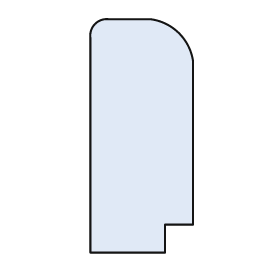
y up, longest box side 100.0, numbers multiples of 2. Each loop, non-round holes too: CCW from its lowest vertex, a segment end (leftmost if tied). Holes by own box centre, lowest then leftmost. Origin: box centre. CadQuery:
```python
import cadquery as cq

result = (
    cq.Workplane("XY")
    .moveTo(-22.0, -50.0)
    .lineTo(10.0, -50.0)
    .lineTo(10.0, -38.0)
    .lineTo(22.0, -38.0)
    .lineTo(22.0, 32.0)
    .threePointArc((16.0, 44.0), (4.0, 50.0))
    .lineTo(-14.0, 50.0)
    .threePointArc((-20.0, 48.0), (-22.0, 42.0))
    .close()
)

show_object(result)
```